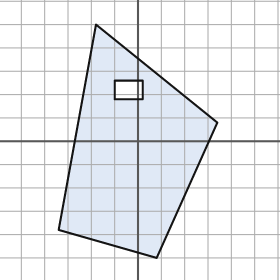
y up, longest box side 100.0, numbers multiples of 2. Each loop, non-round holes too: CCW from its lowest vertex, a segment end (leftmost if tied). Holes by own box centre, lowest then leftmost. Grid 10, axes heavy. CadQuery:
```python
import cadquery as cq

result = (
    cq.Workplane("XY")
    .moveTo(8.0, -50.0)
    .lineTo(34.0, 8.0)
    .lineTo(-18.0, 50.0)
    .lineTo(-34.0, -38.0)
    .close()
    .moveTo(-10.0, 18.0)
    .lineTo(2.0, 18.0)
    .lineTo(2.0, 26.0)
    .lineTo(-10.0, 26.0)
    .close()
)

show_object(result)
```